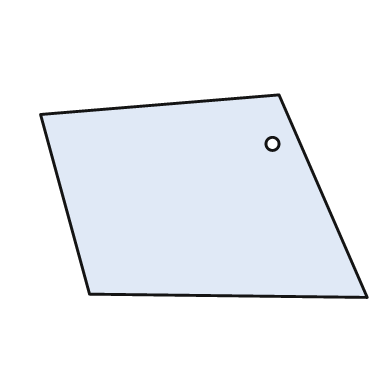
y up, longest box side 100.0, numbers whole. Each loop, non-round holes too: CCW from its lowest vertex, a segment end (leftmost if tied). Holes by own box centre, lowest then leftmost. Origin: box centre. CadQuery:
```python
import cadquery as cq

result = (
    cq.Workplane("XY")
    .moveTo(50.0, -31.0)
    .lineTo(23.0, 31.0)
    .lineTo(-50.0, 25.0)
    .lineTo(-35.0, -30.0)
    .close()
    .moveTo(21.0, 16.0)
    .circle(2.0)
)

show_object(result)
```